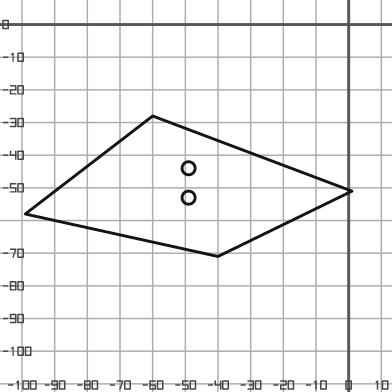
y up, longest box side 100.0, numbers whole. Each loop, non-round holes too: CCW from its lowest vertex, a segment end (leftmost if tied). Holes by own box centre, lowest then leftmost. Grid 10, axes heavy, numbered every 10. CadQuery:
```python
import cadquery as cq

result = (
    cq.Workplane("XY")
    .moveTo(-40.0, -71.0)
    .lineTo(1.0, -51.0)
    .lineTo(-60.0, -28.0)
    .lineTo(-99.0, -58.0)
    .close()
    .moveTo(-49.0, -53.0)
    .circle(2.0)
    .moveTo(-49.0, -44.0)
    .circle(2.0)
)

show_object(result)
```